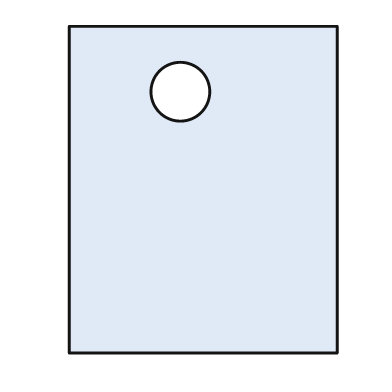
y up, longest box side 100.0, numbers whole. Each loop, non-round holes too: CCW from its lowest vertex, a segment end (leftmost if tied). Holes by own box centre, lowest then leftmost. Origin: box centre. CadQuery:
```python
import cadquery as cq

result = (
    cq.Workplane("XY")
    .moveTo(-41.0, -50.0)
    .lineTo(41.0, -50.0)
    .lineTo(41.0, 50.0)
    .lineTo(-41.0, 50.0)
    .close()
    .moveTo(-7.0, 30.0)
    .circle(9.0)
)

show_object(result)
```